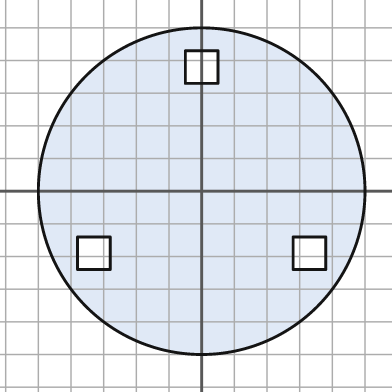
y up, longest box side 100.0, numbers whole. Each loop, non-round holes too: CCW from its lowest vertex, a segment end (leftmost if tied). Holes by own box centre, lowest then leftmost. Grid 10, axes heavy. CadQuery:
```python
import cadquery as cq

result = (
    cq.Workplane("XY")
    .moveTo(0.0, 0.0)
    .circle(50.0)
    .moveTo(-38.0, -24.0)
    .lineTo(-28.0, -24.0)
    .lineTo(-28.0, -14.0)
    .lineTo(-38.0, -14.0)
    .close()
    .moveTo(28.0, -24.0)
    .lineTo(38.0, -24.0)
    .lineTo(38.0, -14.0)
    .lineTo(28.0, -14.0)
    .close()
    .moveTo(-5.0, 33.0)
    .lineTo(5.0, 33.0)
    .lineTo(5.0, 43.0)
    .lineTo(-5.0, 43.0)
    .close()
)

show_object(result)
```